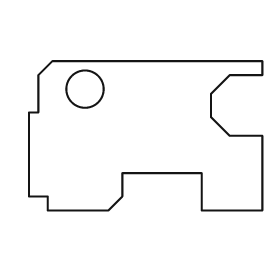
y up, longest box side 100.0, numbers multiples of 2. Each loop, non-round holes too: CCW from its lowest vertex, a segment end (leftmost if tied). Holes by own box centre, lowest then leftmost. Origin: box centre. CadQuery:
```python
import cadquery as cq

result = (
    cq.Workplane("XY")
    .moveTo(-42.0, -32.0)
    .lineTo(-16.0, -32.0)
    .lineTo(-10.0, -26.0)
    .lineTo(-10.0, -16.0)
    .lineTo(24.0, -16.0)
    .lineTo(24.0, -32.0)
    .lineTo(50.0, -32.0)
    .lineTo(50.0, 0.0)
    .lineTo(36.0, 0.0)
    .lineTo(28.0, 8.0)
    .lineTo(28.0, 18.0)
    .lineTo(36.0, 26.0)
    .lineTo(50.0, 26.0)
    .lineTo(50.0, 32.0)
    .lineTo(-40.0, 32.0)
    .lineTo(-46.0, 26.0)
    .lineTo(-46.0, 10.0)
    .lineTo(-50.0, 10.0)
    .lineTo(-50.0, -26.0)
    .lineTo(-42.0, -26.0)
    .close()
    .moveTo(-26.0, 20.0)
    .circle(8.0)
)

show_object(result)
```